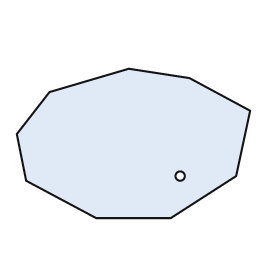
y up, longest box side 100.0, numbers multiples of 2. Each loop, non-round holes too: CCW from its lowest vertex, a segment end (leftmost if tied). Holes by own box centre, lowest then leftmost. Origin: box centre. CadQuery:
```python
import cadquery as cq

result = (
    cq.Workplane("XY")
    .moveTo(-16.0, -32.0)
    .lineTo(16.0, -32.0)
    .lineTo(44.0, -14.0)
    .lineTo(50.0, 14.0)
    .lineTo(24.0, 28.0)
    .lineTo(-2.0, 32.0)
    .lineTo(-36.0, 22.0)
    .lineTo(-50.0, 4.0)
    .lineTo(-46.0, -16.0)
    .close()
    .moveTo(20.0, -14.0)
    .circle(2.0)
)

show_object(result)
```